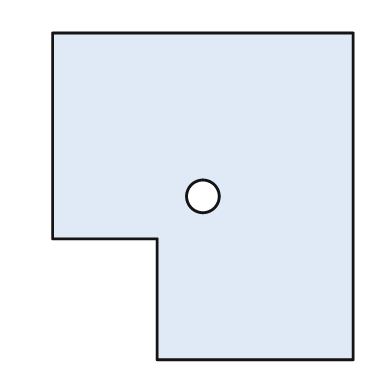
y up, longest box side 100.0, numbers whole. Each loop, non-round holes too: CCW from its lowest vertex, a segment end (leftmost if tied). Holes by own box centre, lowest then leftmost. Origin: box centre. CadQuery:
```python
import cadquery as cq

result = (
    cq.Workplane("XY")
    .moveTo(-14.0, -50.0)
    .lineTo(46.0, -50.0)
    .lineTo(46.0, 50.0)
    .lineTo(-46.0, 50.0)
    .lineTo(-46.0, -13.0)
    .lineTo(-14.0, -13.0)
    .close()
    .moveTo(0.0, 0.0)
    .circle(5.0)
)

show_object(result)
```